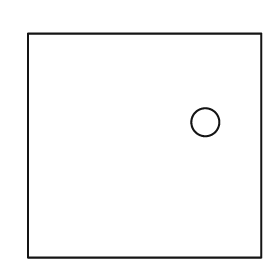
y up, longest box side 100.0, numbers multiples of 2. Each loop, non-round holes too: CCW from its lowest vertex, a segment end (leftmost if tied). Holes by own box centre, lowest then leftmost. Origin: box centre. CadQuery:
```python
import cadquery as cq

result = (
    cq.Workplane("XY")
    .moveTo(-50.0, -48.0)
    .lineTo(50.0, -48.0)
    .lineTo(50.0, 48.0)
    .lineTo(-50.0, 48.0)
    .close()
    .moveTo(26.0, 10.0)
    .circle(6.0)
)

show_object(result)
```